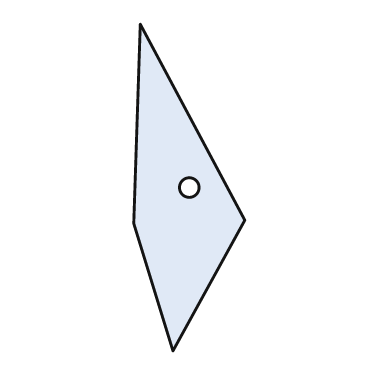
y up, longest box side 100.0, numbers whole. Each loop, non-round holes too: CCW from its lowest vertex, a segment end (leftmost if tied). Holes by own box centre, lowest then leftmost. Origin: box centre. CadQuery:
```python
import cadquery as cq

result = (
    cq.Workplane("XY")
    .moveTo(-5.0, -50.0)
    .lineTo(17.0, -10.0)
    .lineTo(-15.0, 50.0)
    .lineTo(-17.0, -11.0)
    .close()
    .moveTo(0.0, 0.0)
    .circle(3.0)
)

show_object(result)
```